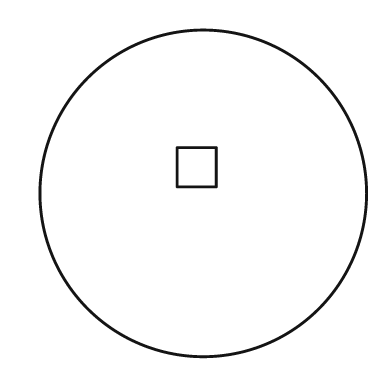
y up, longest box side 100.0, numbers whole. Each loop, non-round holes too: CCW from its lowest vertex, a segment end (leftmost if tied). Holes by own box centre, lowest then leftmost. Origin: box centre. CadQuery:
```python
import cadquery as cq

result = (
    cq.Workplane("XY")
    .moveTo(0.0, 0.0)
    .circle(50.0)
    .moveTo(-8.0, 2.0)
    .lineTo(4.0, 2.0)
    .lineTo(4.0, 14.0)
    .lineTo(-8.0, 14.0)
    .close()
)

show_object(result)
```